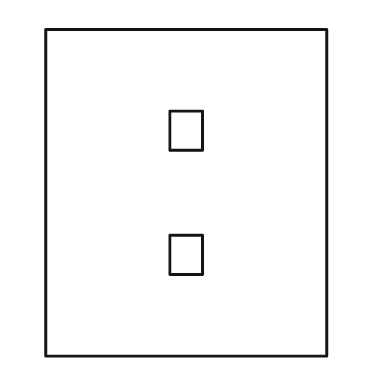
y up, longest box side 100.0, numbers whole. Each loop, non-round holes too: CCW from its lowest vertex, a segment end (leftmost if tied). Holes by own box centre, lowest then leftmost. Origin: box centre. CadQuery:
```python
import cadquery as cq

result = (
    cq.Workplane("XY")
    .moveTo(-43.0, -50.0)
    .lineTo(43.0, -50.0)
    .lineTo(43.0, 50.0)
    .lineTo(-43.0, 50.0)
    .close()
    .moveTo(-5.0, -25.0)
    .lineTo(5.0, -25.0)
    .lineTo(5.0, -13.0)
    .lineTo(-5.0, -13.0)
    .close()
    .moveTo(-5.0, 13.0)
    .lineTo(5.0, 13.0)
    .lineTo(5.0, 25.0)
    .lineTo(-5.0, 25.0)
    .close()
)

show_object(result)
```